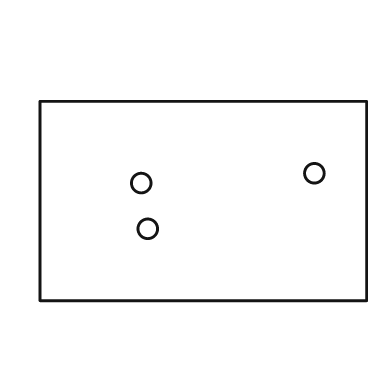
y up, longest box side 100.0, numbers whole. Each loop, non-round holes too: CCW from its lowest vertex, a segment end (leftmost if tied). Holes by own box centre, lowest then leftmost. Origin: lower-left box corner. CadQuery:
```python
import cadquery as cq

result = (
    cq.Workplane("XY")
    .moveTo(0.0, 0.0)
    .lineTo(100.0, 0.0)
    .lineTo(100.0, 61.0)
    .lineTo(0.0, 61.0)
    .close()
    .moveTo(33.0, 22.0)
    .circle(3.0)
    .moveTo(31.0, 36.0)
    .circle(3.0)
    .moveTo(84.0, 39.0)
    .circle(3.0)
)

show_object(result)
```